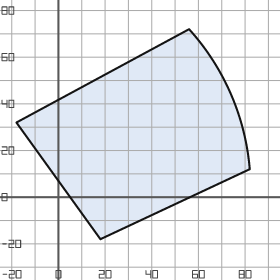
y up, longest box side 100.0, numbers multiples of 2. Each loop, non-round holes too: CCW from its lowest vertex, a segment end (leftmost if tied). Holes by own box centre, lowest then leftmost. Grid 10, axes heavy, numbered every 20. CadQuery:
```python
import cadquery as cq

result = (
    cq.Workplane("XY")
    .moveTo(18.0, -18.0)
    .lineTo(82.0, 12.0)
    .threePointArc((74.0, 44.0), (56.0, 72.0))
    .lineTo(-18.0, 32.0)
    .close()
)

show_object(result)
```